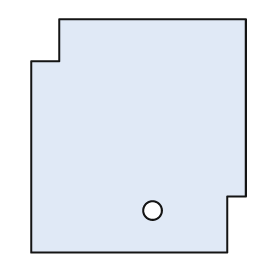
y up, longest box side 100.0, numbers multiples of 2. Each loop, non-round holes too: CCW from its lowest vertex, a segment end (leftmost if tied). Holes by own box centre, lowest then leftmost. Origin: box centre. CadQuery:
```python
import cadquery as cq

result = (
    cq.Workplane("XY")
    .moveTo(-46.0, -50.0)
    .lineTo(38.0, -50.0)
    .lineTo(38.0, -26.0)
    .lineTo(46.0, -26.0)
    .lineTo(46.0, 50.0)
    .lineTo(-34.0, 50.0)
    .lineTo(-34.0, 32.0)
    .lineTo(-46.0, 32.0)
    .close()
    .moveTo(6.0, -32.0)
    .circle(4.0)
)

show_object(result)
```